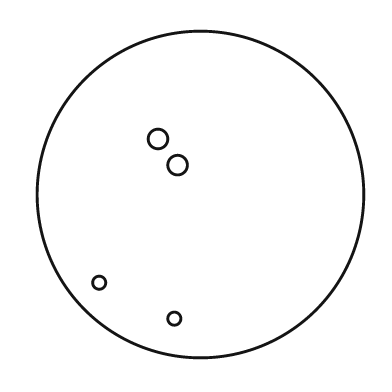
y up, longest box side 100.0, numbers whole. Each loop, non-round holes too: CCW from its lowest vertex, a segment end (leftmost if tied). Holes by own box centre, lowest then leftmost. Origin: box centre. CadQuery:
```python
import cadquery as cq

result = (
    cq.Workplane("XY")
    .moveTo(0.0, 0.0)
    .circle(50.0)
    .moveTo(-8.0, -38.0)
    .circle(2.0)
    .moveTo(-31.0, -27.0)
    .circle(2.0)
    .moveTo(-7.0, 9.0)
    .circle(3.0)
    .moveTo(-13.0, 17.0)
    .circle(3.0)
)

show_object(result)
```